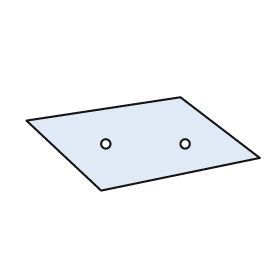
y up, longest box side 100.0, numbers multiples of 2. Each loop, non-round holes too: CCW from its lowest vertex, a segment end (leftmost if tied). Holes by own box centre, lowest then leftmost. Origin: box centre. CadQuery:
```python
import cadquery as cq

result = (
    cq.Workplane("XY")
    .moveTo(-18.0, -20.0)
    .lineTo(50.0, -6.0)
    .lineTo(16.0, 20.0)
    .lineTo(-50.0, 10.0)
    .close()
    .moveTo(-16.0, 0.0)
    .circle(2.0)
    .moveTo(18.0, 0.0)
    .circle(2.0)
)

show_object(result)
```